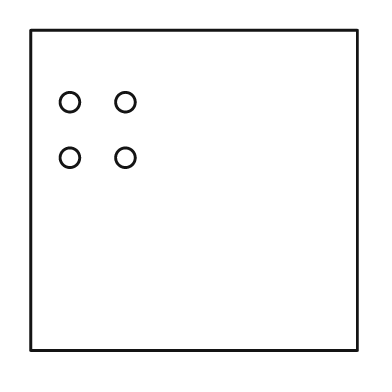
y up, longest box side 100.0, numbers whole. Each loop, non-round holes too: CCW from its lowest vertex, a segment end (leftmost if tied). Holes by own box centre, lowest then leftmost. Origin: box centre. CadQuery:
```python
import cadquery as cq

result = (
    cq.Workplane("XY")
    .moveTo(-50.0, -49.0)
    .lineTo(50.0, -49.0)
    .lineTo(50.0, 49.0)
    .lineTo(-50.0, 49.0)
    .close()
    .moveTo(-38.0, 10.0)
    .circle(3.0)
    .moveTo(-21.0, 10.0)
    .circle(3.0)
    .moveTo(-38.0, 27.0)
    .circle(3.0)
    .moveTo(-21.0, 27.0)
    .circle(3.0)
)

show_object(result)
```